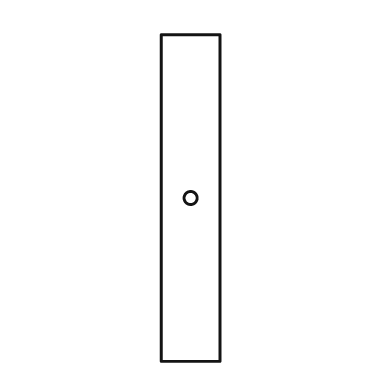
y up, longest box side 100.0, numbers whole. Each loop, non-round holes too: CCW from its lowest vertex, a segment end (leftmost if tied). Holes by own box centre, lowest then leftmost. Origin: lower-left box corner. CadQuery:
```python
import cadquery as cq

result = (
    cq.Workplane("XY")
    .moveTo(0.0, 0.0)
    .lineTo(18.0, 0.0)
    .lineTo(18.0, 100.0)
    .lineTo(0.0, 100.0)
    .close()
    .moveTo(9.0, 50.0)
    .circle(2.0)
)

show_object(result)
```